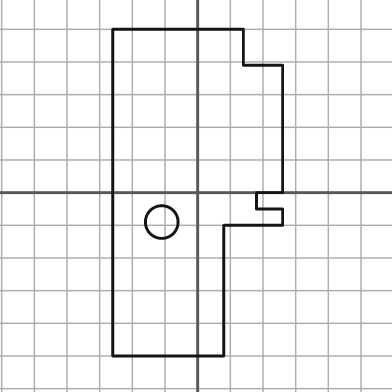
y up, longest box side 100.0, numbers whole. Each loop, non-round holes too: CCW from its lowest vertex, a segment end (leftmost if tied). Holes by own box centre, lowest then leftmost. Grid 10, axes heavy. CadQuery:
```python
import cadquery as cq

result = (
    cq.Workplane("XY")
    .moveTo(-26.0, -50.0)
    .lineTo(8.0, -50.0)
    .lineTo(8.0, -10.0)
    .lineTo(26.0, -10.0)
    .lineTo(26.0, -5.0)
    .lineTo(18.0, -5.0)
    .lineTo(18.0, 0.0)
    .lineTo(26.0, 0.0)
    .lineTo(26.0, 39.0)
    .lineTo(14.0, 39.0)
    .lineTo(14.0, 50.0)
    .lineTo(-26.0, 50.0)
    .close()
    .moveTo(-11.0, -9.0)
    .circle(5.0)
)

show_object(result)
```